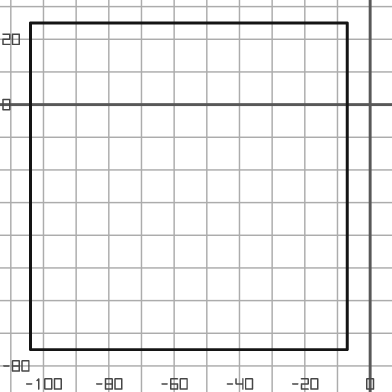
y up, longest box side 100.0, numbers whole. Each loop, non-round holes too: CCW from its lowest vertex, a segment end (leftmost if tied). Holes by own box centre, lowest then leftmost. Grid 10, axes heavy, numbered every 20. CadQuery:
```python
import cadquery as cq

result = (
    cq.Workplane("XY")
    .moveTo(-104.0, -75.0)
    .lineTo(-7.0, -75.0)
    .lineTo(-7.0, 25.0)
    .lineTo(-104.0, 25.0)
    .close()
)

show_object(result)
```